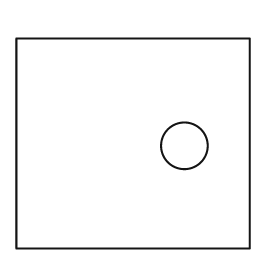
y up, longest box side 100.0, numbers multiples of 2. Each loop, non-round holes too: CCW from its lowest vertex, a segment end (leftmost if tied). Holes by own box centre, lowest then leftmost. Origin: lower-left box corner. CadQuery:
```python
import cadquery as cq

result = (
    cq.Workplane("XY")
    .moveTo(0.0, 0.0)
    .lineTo(100.0, 0.0)
    .lineTo(100.0, 90.0)
    .lineTo(0.0, 90.0)
    .close()
    .moveTo(72.0, 44.0)
    .circle(10.0)
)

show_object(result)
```